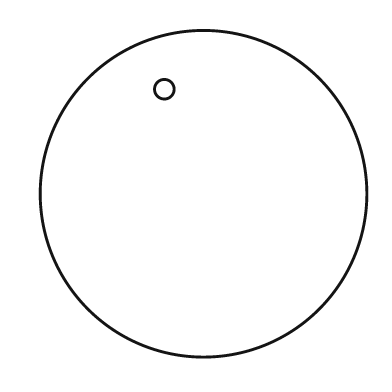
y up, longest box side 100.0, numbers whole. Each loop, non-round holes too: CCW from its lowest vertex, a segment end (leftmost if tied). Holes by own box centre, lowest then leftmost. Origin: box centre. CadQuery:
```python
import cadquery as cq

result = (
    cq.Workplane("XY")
    .moveTo(0.0, 0.0)
    .circle(50.0)
    .moveTo(-12.0, 32.0)
    .circle(3.0)
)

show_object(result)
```